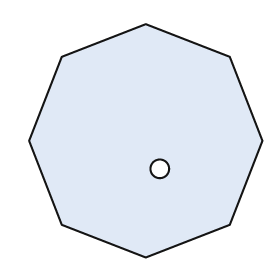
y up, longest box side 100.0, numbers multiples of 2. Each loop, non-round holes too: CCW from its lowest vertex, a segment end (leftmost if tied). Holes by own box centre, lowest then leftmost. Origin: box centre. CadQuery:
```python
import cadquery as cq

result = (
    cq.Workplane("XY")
    .moveTo(0.0, -50.0)
    .lineTo(36.0, -36.0)
    .lineTo(50.0, 0.0)
    .lineTo(36.0, 36.0)
    .lineTo(0.0, 50.0)
    .lineTo(-36.0, 36.0)
    .lineTo(-50.0, 0.0)
    .lineTo(-36.0, -36.0)
    .close()
    .moveTo(6.0, -12.0)
    .circle(4.0)
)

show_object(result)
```